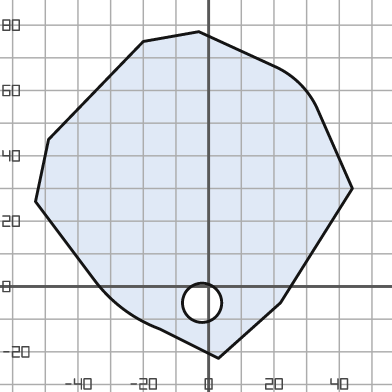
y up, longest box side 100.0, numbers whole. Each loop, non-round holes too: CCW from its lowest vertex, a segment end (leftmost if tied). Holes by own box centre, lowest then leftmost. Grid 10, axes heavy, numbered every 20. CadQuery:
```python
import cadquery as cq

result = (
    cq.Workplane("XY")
    .moveTo(3.0, -22.0)
    .lineTo(22.0, -5.0)
    .lineTo(44.0, 30.0)
    .lineTo(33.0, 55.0)
    .threePointArc((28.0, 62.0), (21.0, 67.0))
    .lineTo(-3.0, 78.0)
    .lineTo(-20.0, 75.0)
    .lineTo(-49.0, 45.0)
    .lineTo(-53.0, 26.0)
    .lineTo(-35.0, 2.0)
    .threePointArc((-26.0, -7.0), (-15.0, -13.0))
    .close()
    .moveTo(-2.0, -5.0)
    .circle(6.0)
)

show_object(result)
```